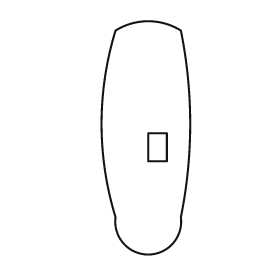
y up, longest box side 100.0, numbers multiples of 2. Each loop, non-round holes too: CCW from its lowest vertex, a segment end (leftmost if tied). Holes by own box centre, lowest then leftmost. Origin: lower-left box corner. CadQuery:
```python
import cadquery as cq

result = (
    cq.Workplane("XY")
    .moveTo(6.0, 16.0)
    .threePointArc((20.0, 0.0), (34.0, 16.0))
    .threePointArc((38.0, 56.0), (34.0, 96.0))
    .threePointArc((20.0, 100.0), (6.0, 96.0))
    .threePointArc((0.0, 56.0), (6.0, 16.0))
    .close()
    .moveTo(20.0, 40.0)
    .lineTo(28.0, 40.0)
    .lineTo(28.0, 52.0)
    .lineTo(20.0, 52.0)
    .close()
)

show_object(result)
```